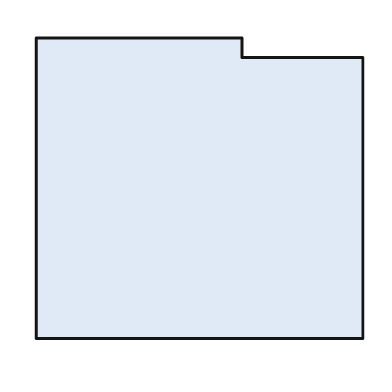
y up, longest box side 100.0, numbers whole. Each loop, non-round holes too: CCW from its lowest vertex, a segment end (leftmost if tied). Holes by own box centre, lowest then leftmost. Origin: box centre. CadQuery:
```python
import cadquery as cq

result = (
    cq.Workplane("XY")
    .moveTo(-50.0, -46.0)
    .lineTo(50.0, -46.0)
    .lineTo(50.0, 40.0)
    .lineTo(13.0, 40.0)
    .lineTo(13.0, 46.0)
    .lineTo(-50.0, 46.0)
    .close()
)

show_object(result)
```